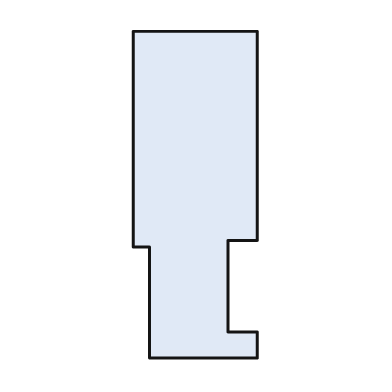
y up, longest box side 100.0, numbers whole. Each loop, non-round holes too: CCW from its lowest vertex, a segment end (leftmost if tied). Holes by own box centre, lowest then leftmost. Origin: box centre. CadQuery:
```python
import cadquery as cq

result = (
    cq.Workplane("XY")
    .moveTo(-14.0, -50.0)
    .lineTo(19.0, -50.0)
    .lineTo(19.0, -42.0)
    .lineTo(10.0, -42.0)
    .lineTo(10.0, -14.0)
    .lineTo(19.0, -14.0)
    .lineTo(19.0, 50.0)
    .lineTo(-19.0, 50.0)
    .lineTo(-19.0, -16.0)
    .lineTo(-14.0, -16.0)
    .close()
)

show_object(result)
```